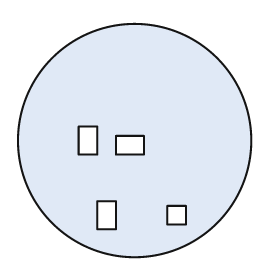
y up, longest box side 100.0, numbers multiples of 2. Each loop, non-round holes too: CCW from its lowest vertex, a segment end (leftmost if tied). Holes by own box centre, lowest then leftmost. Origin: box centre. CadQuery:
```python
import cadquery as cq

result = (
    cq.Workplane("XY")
    .moveTo(0.0, 0.0)
    .circle(50.0)
    .moveTo(-16.0, -38.0)
    .lineTo(-8.0, -38.0)
    .lineTo(-8.0, -26.0)
    .lineTo(-16.0, -26.0)
    .close()
    .moveTo(14.0, -36.0)
    .lineTo(22.0, -36.0)
    .lineTo(22.0, -28.0)
    .lineTo(14.0, -28.0)
    .close()
    .moveTo(-8.0, -6.0)
    .lineTo(4.0, -6.0)
    .lineTo(4.0, 2.0)
    .lineTo(-8.0, 2.0)
    .close()
    .moveTo(-24.0, -6.0)
    .lineTo(-16.0, -6.0)
    .lineTo(-16.0, 6.0)
    .lineTo(-24.0, 6.0)
    .close()
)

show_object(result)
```